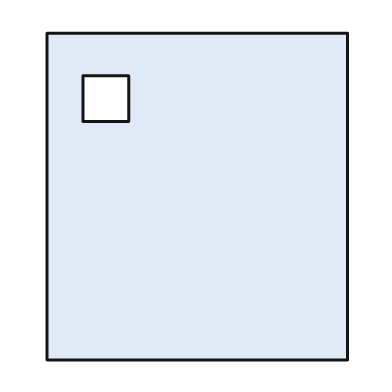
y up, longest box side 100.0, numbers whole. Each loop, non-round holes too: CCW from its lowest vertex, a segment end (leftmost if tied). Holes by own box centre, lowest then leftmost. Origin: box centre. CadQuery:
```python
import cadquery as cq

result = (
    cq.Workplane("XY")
    .moveTo(-46.0, -50.0)
    .lineTo(46.0, -50.0)
    .lineTo(46.0, 50.0)
    .lineTo(-46.0, 50.0)
    .close()
    .moveTo(-35.0, 23.0)
    .lineTo(-21.0, 23.0)
    .lineTo(-21.0, 37.0)
    .lineTo(-35.0, 37.0)
    .close()
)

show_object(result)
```